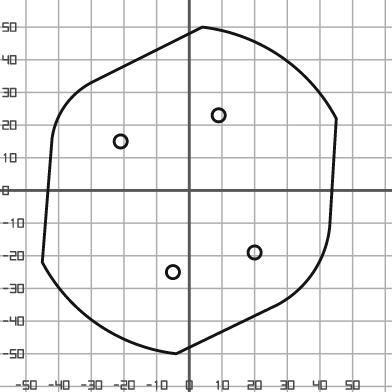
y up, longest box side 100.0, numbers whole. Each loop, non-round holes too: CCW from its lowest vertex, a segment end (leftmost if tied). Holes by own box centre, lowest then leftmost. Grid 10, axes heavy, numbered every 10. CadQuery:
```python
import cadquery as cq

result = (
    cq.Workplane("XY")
    .moveTo(-4.0, -50.0)
    .lineTo(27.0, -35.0)
    .threePointArc((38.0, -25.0), (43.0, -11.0))
    .lineTo(45.0, 22.0)
    .threePointArc((28.0, 41.0), (4.0, 50.0))
    .lineTo(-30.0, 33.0)
    .threePointArc((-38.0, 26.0), (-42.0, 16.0))
    .lineTo(-45.0, -22.0)
    .threePointArc((-28.0, -41.0), (-4.0, -50.0))
    .close()
    .moveTo(-5.0, -25.0)
    .circle(2.0)
    .moveTo(20.0, -19.0)
    .circle(2.0)
    .moveTo(-21.0, 15.0)
    .circle(2.0)
    .moveTo(9.0, 23.0)
    .circle(2.0)
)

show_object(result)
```